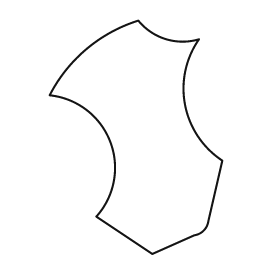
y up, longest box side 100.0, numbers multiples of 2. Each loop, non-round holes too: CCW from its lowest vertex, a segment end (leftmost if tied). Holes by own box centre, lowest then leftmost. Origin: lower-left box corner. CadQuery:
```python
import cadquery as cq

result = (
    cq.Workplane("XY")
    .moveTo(44.0, 0.0)
    .lineTo(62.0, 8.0)
    .threePointArc((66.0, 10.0), (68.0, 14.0))
    .lineTo(74.0, 40.0)
    .threePointArc((58.0, 64.0), (64.0, 92.0))
    .threePointArc((50.0, 92.0), (38.0, 100.0))
    .threePointArc((16.0, 88.0), (0.0, 68.0))
    .threePointArc((26.0, 48.0), (20.0, 16.0))
    .close()
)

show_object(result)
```